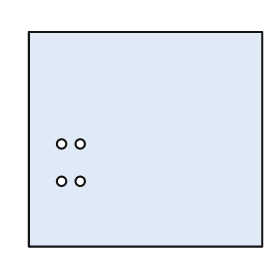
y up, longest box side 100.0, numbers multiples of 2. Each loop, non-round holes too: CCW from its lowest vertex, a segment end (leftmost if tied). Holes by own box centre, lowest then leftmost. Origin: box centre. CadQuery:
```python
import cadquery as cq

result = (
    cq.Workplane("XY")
    .moveTo(-50.0, -46.0)
    .lineTo(50.0, -46.0)
    .lineTo(50.0, 46.0)
    .lineTo(-50.0, 46.0)
    .close()
    .moveTo(-36.0, -18.0)
    .circle(2.0)
    .moveTo(-28.0, -18.0)
    .circle(2.0)
    .moveTo(-36.0, -2.0)
    .circle(2.0)
    .moveTo(-28.0, -2.0)
    .circle(2.0)
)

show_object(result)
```